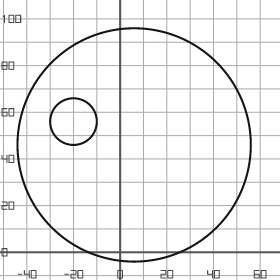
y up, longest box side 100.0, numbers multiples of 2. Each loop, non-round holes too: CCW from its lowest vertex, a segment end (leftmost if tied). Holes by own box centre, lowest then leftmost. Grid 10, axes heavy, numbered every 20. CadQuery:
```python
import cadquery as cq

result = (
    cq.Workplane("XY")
    .moveTo(6.0, 46.0)
    .circle(50.0)
    .moveTo(-20.0, 56.0)
    .circle(10.0)
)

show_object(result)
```